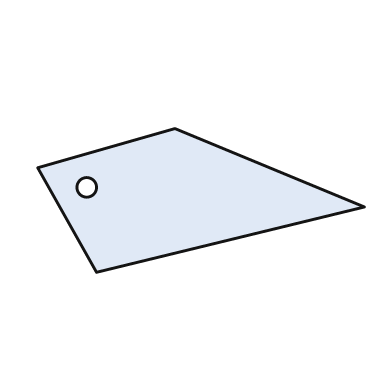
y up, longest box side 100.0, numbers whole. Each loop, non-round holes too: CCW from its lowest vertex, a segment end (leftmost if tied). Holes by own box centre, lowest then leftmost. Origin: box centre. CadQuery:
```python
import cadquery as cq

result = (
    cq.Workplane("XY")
    .moveTo(-32.0, -22.0)
    .lineTo(50.0, -2.0)
    .lineTo(-8.0, 22.0)
    .lineTo(-50.0, 10.0)
    .close()
    .moveTo(-35.0, 4.0)
    .circle(3.0)
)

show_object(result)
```